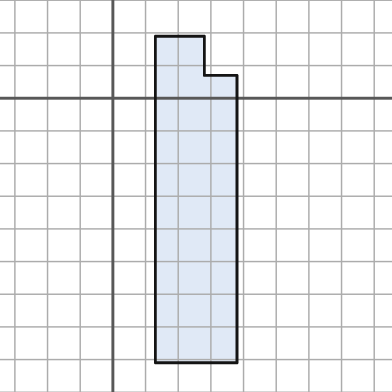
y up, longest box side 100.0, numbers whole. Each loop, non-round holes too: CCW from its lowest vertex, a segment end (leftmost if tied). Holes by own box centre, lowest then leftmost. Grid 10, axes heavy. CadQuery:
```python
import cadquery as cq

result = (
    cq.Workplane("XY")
    .moveTo(13.0, -81.0)
    .lineTo(38.0, -81.0)
    .lineTo(38.0, 7.0)
    .lineTo(28.0, 7.0)
    .lineTo(28.0, 19.0)
    .lineTo(13.0, 19.0)
    .close()
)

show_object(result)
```